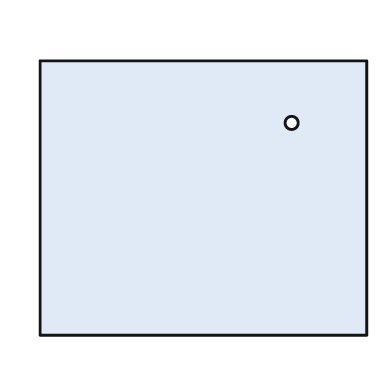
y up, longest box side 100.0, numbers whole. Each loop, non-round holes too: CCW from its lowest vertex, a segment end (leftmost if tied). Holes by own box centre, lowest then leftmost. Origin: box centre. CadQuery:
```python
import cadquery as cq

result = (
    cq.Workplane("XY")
    .moveTo(-50.0, -42.0)
    .lineTo(50.0, -42.0)
    .lineTo(50.0, 42.0)
    .lineTo(-50.0, 42.0)
    .close()
    .moveTo(27.0, 23.0)
    .circle(2.0)
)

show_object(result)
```